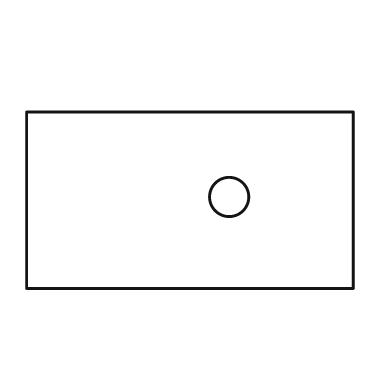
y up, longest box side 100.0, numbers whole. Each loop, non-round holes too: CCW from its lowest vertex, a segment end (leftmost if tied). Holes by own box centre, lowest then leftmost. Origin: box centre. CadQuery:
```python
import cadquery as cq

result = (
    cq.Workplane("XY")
    .moveTo(-50.0, -27.0)
    .lineTo(50.0, -27.0)
    .lineTo(50.0, 27.0)
    .lineTo(-50.0, 27.0)
    .close()
    .moveTo(12.0, 1.0)
    .circle(6.0)
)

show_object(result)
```